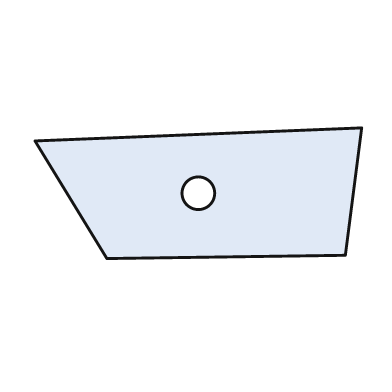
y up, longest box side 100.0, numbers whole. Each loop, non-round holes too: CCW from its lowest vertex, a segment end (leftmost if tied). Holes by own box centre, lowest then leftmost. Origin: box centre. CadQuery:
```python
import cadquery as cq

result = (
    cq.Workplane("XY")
    .moveTo(-28.0, -20.0)
    .lineTo(45.0, -19.0)
    .lineTo(50.0, 20.0)
    .lineTo(-50.0, 16.0)
    .close()
    .moveTo(0.0, 0.0)
    .circle(5.0)
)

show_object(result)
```